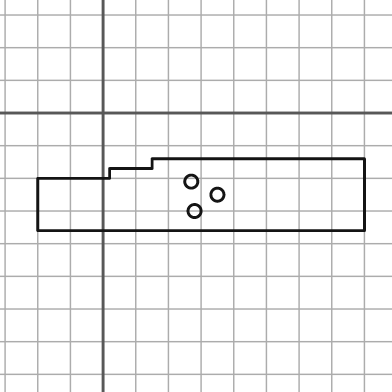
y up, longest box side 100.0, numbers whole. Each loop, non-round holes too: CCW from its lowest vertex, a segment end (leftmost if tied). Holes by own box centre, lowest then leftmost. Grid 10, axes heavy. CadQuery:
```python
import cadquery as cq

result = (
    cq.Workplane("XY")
    .moveTo(-20.0, -36.0)
    .lineTo(80.0, -36.0)
    .lineTo(80.0, -14.0)
    .lineTo(15.0, -14.0)
    .lineTo(15.0, -17.0)
    .lineTo(2.0, -17.0)
    .lineTo(2.0, -20.0)
    .lineTo(-20.0, -20.0)
    .close()
    .moveTo(28.0, -30.0)
    .circle(2.0)
    .moveTo(35.0, -25.0)
    .circle(2.0)
    .moveTo(27.0, -21.0)
    .circle(2.0)
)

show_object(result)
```